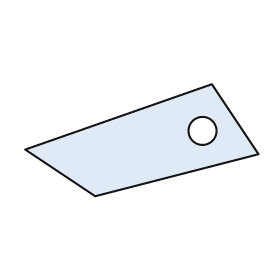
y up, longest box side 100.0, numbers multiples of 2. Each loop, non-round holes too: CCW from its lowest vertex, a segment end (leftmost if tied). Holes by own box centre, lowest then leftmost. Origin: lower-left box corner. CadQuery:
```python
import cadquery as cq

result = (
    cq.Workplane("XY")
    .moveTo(30.0, 0.0)
    .lineTo(100.0, 18.0)
    .lineTo(80.0, 48.0)
    .lineTo(0.0, 20.0)
    .close()
    .moveTo(76.0, 28.0)
    .circle(6.0)
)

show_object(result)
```